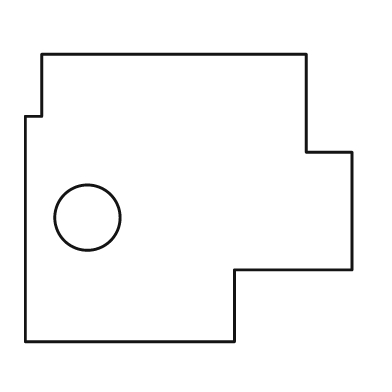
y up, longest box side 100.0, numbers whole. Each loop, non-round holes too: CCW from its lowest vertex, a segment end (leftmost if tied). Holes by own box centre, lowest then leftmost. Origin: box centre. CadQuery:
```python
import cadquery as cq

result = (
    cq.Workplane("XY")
    .moveTo(-50.0, -44.0)
    .lineTo(14.0, -44.0)
    .lineTo(14.0, -22.0)
    .lineTo(50.0, -22.0)
    .lineTo(50.0, 14.0)
    .lineTo(36.0, 14.0)
    .lineTo(36.0, 44.0)
    .lineTo(-45.0, 44.0)
    .lineTo(-45.0, 25.0)
    .lineTo(-50.0, 25.0)
    .close()
    .moveTo(-31.0, -6.0)
    .circle(10.0)
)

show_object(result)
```